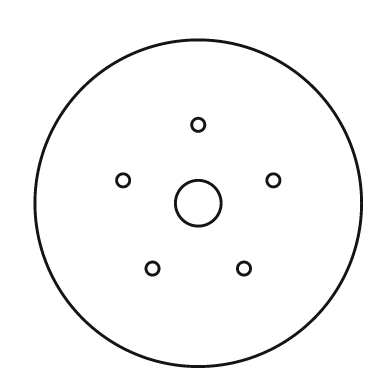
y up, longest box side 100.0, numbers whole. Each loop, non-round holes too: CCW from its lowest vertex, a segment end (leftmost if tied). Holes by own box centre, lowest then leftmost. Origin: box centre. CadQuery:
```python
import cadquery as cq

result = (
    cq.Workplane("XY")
    .moveTo(0.0, 0.0)
    .circle(50.0)
    .moveTo(-14.0, -20.0)
    .circle(2.0)
    .moveTo(14.0, -20.0)
    .circle(2.0)
    .moveTo(0.0, 0.0)
    .circle(7.0)
    .moveTo(-23.0, 7.0)
    .circle(2.0)
    .moveTo(23.0, 7.0)
    .circle(2.0)
    .moveTo(0.0, 24.0)
    .circle(2.0)
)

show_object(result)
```